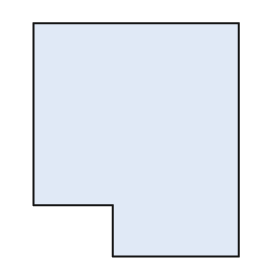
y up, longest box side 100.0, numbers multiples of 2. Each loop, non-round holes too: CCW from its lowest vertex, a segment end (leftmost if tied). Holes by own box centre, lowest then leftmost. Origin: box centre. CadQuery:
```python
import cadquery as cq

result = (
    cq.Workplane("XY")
    .moveTo(-10.0, -50.0)
    .lineTo(44.0, -50.0)
    .lineTo(44.0, 50.0)
    .lineTo(-44.0, 50.0)
    .lineTo(-44.0, -28.0)
    .lineTo(-10.0, -28.0)
    .close()
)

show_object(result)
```